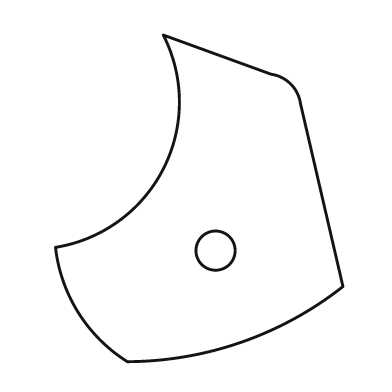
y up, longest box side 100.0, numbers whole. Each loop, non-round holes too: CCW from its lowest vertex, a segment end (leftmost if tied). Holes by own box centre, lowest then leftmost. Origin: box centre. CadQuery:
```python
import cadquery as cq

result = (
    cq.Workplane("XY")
    .moveTo(-22.0, -50.0)
    .threePointArc((13.0, -44.0), (44.0, -27.0))
    .lineTo(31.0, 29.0)
    .threePointArc((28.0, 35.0), (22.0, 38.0))
    .lineTo(-11.0, 50.0)
    .threePointArc((-11.0, 9.0), (-44.0, -15.0))
    .threePointArc((-37.0, -35.0), (-22.0, -50.0))
    .close()
    .moveTo(5.0, -16.0)
    .circle(6.0)
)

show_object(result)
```